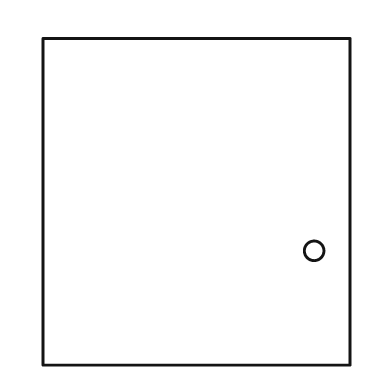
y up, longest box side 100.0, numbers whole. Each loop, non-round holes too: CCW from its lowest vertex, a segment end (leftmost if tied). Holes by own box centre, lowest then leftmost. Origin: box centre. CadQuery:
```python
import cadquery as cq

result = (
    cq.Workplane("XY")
    .moveTo(-47.0, -50.0)
    .lineTo(47.0, -50.0)
    .lineTo(47.0, 50.0)
    .lineTo(-47.0, 50.0)
    .close()
    .moveTo(36.0, -15.0)
    .circle(3.0)
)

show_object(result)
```